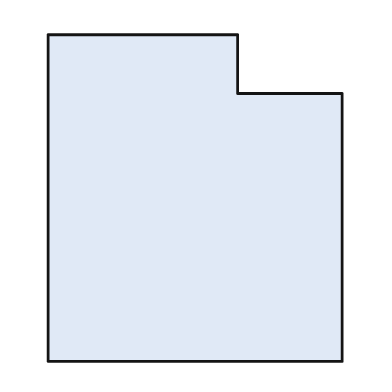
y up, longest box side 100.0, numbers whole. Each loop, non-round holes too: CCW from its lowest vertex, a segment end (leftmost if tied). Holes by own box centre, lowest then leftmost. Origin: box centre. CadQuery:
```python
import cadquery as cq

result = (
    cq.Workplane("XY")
    .moveTo(-45.0, -50.0)
    .lineTo(45.0, -50.0)
    .lineTo(45.0, 32.0)
    .lineTo(13.0, 32.0)
    .lineTo(13.0, 50.0)
    .lineTo(-45.0, 50.0)
    .close()
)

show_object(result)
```